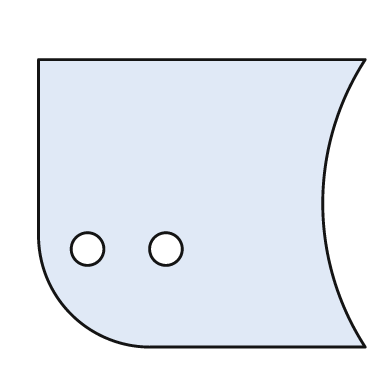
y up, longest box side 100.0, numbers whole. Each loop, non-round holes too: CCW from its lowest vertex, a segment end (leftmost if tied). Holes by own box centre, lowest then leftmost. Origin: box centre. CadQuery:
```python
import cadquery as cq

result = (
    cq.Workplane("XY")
    .moveTo(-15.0, -44.0)
    .lineTo(50.0, -44.0)
    .threePointArc((37.0, 0.0), (50.0, 44.0))
    .lineTo(-50.0, 44.0)
    .lineTo(-50.0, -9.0)
    .threePointArc((-40.0, -34.0), (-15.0, -44.0))
    .close()
    .moveTo(-35.0, -14.0)
    .circle(5.0)
    .moveTo(-11.0, -14.0)
    .circle(5.0)
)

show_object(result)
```